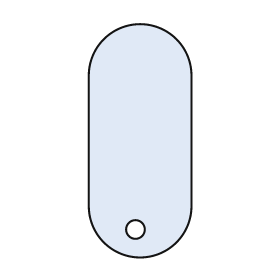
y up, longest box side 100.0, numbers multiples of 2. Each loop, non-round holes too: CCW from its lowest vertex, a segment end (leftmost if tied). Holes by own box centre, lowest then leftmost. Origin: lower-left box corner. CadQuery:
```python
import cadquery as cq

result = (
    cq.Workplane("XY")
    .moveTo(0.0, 22.0)
    .threePointArc((22.0, 0.0), (44.0, 22.0))
    .lineTo(44.0, 78.0)
    .threePointArc((22.0, 100.0), (0.0, 78.0))
    .close()
    .moveTo(20.0, 12.0)
    .circle(4.0)
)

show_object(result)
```